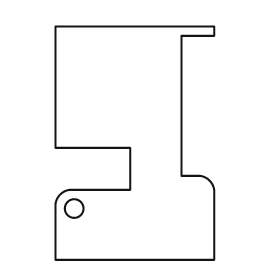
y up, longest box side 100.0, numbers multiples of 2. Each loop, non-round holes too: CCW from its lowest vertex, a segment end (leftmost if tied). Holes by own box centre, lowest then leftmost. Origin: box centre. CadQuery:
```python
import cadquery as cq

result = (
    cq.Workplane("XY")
    .moveTo(-34.0, -50.0)
    .lineTo(34.0, -50.0)
    .lineTo(34.0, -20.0)
    .threePointArc((32.0, -16.0), (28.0, -14.0))
    .lineTo(20.0, -14.0)
    .lineTo(20.0, 46.0)
    .lineTo(34.0, 46.0)
    .lineTo(34.0, 50.0)
    .lineTo(-34.0, 50.0)
    .lineTo(-34.0, -2.0)
    .lineTo(-2.0, -2.0)
    .lineTo(-2.0, -20.0)
    .lineTo(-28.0, -20.0)
    .threePointArc((-32.0, -22.0), (-34.0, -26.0))
    .close()
    .moveTo(-26.0, -28.0)
    .circle(4.0)
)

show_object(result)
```